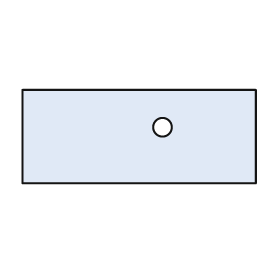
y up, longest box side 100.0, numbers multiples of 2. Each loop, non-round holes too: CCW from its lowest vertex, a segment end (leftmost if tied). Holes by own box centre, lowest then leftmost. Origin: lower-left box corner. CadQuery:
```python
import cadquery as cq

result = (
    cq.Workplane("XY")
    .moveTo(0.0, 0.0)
    .lineTo(100.0, 0.0)
    .lineTo(100.0, 40.0)
    .lineTo(0.0, 40.0)
    .close()
    .moveTo(60.0, 24.0)
    .circle(4.0)
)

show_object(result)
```